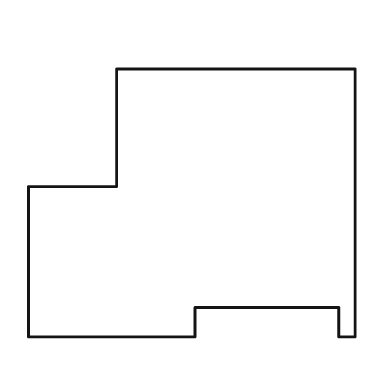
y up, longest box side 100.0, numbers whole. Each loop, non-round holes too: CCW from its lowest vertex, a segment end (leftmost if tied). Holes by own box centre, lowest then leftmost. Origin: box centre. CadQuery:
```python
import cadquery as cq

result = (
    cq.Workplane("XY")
    .moveTo(-50.0, -41.0)
    .lineTo(1.0, -41.0)
    .lineTo(1.0, -32.0)
    .lineTo(45.0, -32.0)
    .lineTo(45.0, -41.0)
    .lineTo(50.0, -41.0)
    .lineTo(50.0, 41.0)
    .lineTo(-23.0, 41.0)
    .lineTo(-23.0, 5.0)
    .lineTo(-50.0, 5.0)
    .close()
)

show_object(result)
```